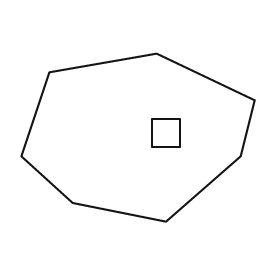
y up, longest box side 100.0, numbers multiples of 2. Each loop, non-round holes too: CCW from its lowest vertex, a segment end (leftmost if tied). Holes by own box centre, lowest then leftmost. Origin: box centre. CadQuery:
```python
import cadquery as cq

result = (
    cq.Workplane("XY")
    .moveTo(12.0, -36.0)
    .lineTo(44.0, -8.0)
    .lineTo(50.0, 16.0)
    .lineTo(8.0, 36.0)
    .lineTo(-38.0, 28.0)
    .lineTo(-50.0, -8.0)
    .lineTo(-28.0, -28.0)
    .close()
    .moveTo(6.0, -4.0)
    .lineTo(18.0, -4.0)
    .lineTo(18.0, 8.0)
    .lineTo(6.0, 8.0)
    .close()
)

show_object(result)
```